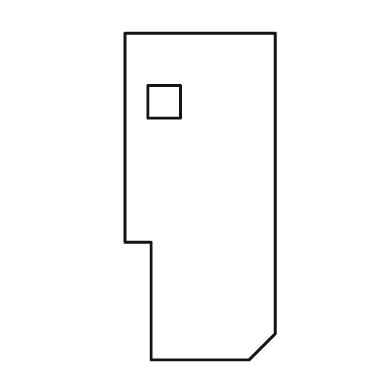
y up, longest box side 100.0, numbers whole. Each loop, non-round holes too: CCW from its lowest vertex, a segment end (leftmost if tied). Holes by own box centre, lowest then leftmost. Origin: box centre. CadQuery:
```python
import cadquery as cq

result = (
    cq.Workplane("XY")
    .moveTo(-15.0, -50.0)
    .lineTo(15.0, -50.0)
    .lineTo(23.0, -42.0)
    .lineTo(23.0, 50.0)
    .lineTo(-23.0, 50.0)
    .lineTo(-23.0, -14.0)
    .lineTo(-15.0, -14.0)
    .close()
    .moveTo(-16.0, 24.0)
    .lineTo(-6.0, 24.0)
    .lineTo(-6.0, 34.0)
    .lineTo(-16.0, 34.0)
    .close()
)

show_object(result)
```